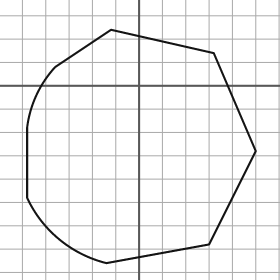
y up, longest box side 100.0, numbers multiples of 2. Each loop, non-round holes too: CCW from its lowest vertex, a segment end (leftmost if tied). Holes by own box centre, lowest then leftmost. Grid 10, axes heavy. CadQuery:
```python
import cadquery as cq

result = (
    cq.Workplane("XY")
    .moveTo(-14.0, -76.0)
    .lineTo(30.0, -68.0)
    .lineTo(50.0, -28.0)
    .lineTo(32.0, 14.0)
    .lineTo(-12.0, 24.0)
    .lineTo(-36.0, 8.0)
    .threePointArc((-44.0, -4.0), (-48.0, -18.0))
    .lineTo(-48.0, -48.0)
    .threePointArc((-34.0, -66.0), (-14.0, -76.0))
    .close()
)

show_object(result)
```